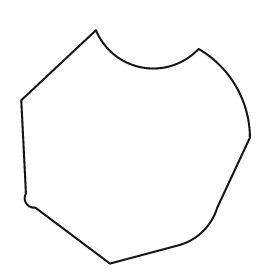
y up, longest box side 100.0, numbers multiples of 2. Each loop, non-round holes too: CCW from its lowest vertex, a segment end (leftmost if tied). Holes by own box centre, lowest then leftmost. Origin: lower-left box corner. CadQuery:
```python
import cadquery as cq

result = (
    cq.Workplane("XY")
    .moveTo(38.0, 0.0)
    .lineTo(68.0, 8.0)
    .threePointArc((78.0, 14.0), (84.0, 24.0))
    .lineTo(98.0, 54.0)
    .threePointArc((92.0, 76.0), (76.0, 92.0))
    .threePointArc((52.0, 84.0), (32.0, 100.0))
    .lineTo(0.0, 70.0)
    .lineTo(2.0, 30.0)
    .threePointArc((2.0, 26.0), (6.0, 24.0))
    .close()
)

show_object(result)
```